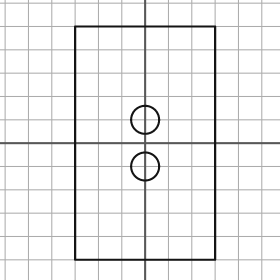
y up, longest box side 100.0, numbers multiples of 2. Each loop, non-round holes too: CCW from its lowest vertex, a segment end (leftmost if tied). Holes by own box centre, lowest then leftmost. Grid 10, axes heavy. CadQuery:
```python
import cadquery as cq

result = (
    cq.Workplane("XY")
    .moveTo(-30.0, -50.0)
    .lineTo(30.0, -50.0)
    .lineTo(30.0, 50.0)
    .lineTo(-30.0, 50.0)
    .close()
    .moveTo(0.0, -10.0)
    .circle(6.0)
    .moveTo(0.0, 10.0)
    .circle(6.0)
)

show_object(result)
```